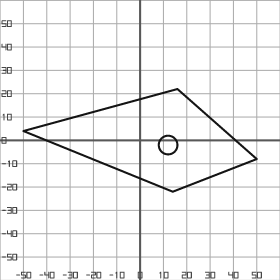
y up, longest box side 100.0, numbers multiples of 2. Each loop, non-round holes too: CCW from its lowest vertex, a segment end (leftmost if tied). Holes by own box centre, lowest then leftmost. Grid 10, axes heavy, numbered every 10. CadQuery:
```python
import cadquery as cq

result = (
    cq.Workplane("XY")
    .moveTo(14.0, -22.0)
    .lineTo(50.0, -8.0)
    .lineTo(16.0, 22.0)
    .lineTo(-50.0, 4.0)
    .close()
    .moveTo(12.0, -2.0)
    .circle(4.0)
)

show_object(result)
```